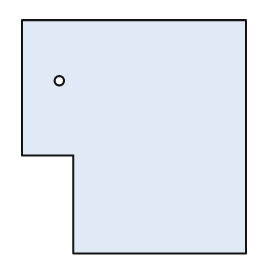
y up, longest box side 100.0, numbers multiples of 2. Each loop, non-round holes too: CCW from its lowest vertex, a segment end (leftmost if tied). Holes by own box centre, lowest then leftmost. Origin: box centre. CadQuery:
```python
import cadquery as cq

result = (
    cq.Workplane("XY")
    .moveTo(-26.0, -50.0)
    .lineTo(48.0, -50.0)
    .lineTo(48.0, 50.0)
    .lineTo(-48.0, 50.0)
    .lineTo(-48.0, -8.0)
    .lineTo(-26.0, -8.0)
    .close()
    .moveTo(-32.0, 24.0)
    .circle(2.0)
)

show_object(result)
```